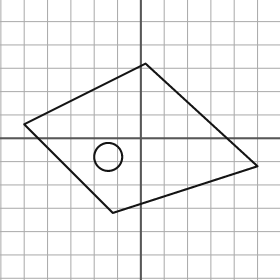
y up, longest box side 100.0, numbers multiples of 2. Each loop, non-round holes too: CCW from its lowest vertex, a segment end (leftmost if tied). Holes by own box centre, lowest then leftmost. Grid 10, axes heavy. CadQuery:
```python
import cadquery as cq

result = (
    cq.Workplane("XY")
    .moveTo(-12.0, -32.0)
    .lineTo(50.0, -12.0)
    .lineTo(2.0, 32.0)
    .lineTo(-50.0, 6.0)
    .close()
    .moveTo(-14.0, -8.0)
    .circle(6.0)
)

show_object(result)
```